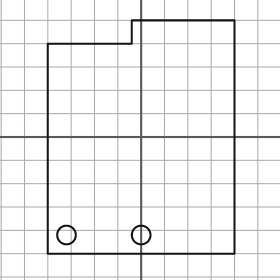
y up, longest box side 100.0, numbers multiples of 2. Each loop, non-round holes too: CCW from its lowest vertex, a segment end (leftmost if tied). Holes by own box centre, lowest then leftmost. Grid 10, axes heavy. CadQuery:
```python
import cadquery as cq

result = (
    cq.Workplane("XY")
    .moveTo(-40.0, -50.0)
    .lineTo(40.0, -50.0)
    .lineTo(40.0, 50.0)
    .lineTo(-4.0, 50.0)
    .lineTo(-4.0, 40.0)
    .lineTo(-40.0, 40.0)
    .close()
    .moveTo(-32.0, -42.0)
    .circle(4.0)
    .moveTo(0.0, -42.0)
    .circle(4.0)
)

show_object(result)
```